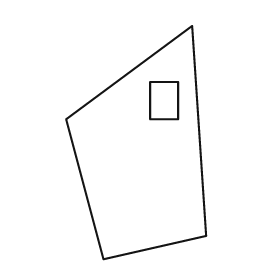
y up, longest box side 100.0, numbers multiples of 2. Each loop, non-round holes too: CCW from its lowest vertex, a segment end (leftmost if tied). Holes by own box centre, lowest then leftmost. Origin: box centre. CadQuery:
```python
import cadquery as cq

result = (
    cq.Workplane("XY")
    .moveTo(-14.0, -50.0)
    .lineTo(30.0, -40.0)
    .lineTo(24.0, 50.0)
    .lineTo(-30.0, 10.0)
    .close()
    .moveTo(6.0, 10.0)
    .lineTo(18.0, 10.0)
    .lineTo(18.0, 26.0)
    .lineTo(6.0, 26.0)
    .close()
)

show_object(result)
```